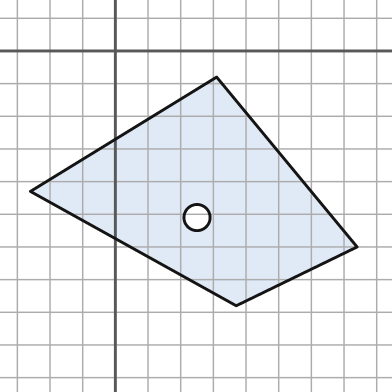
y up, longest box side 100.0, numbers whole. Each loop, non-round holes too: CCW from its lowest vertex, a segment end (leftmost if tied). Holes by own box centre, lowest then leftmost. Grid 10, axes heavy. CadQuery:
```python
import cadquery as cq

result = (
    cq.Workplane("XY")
    .moveTo(37.0, -78.0)
    .lineTo(74.0, -60.0)
    .lineTo(31.0, -8.0)
    .lineTo(-26.0, -43.0)
    .close()
    .moveTo(25.0, -51.0)
    .circle(4.0)
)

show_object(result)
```